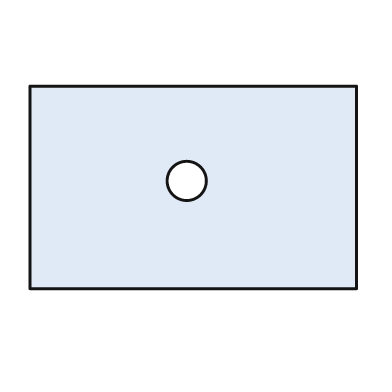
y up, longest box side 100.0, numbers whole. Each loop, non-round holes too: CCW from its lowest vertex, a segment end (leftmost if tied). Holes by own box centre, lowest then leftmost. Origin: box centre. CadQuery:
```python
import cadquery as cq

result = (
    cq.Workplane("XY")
    .moveTo(-50.0, -31.0)
    .lineTo(50.0, -31.0)
    .lineTo(50.0, 31.0)
    .lineTo(-50.0, 31.0)
    .close()
    .moveTo(-2.0, 2.0)
    .circle(6.0)
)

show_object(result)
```